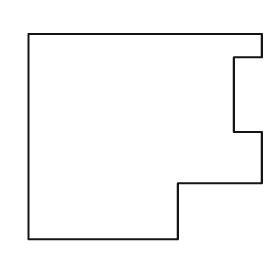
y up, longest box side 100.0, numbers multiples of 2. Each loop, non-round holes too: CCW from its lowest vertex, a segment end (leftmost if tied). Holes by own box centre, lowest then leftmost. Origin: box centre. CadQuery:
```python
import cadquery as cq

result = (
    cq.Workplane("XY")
    .moveTo(-50.0, -44.0)
    .lineTo(14.0, -44.0)
    .lineTo(14.0, -20.0)
    .lineTo(50.0, -20.0)
    .lineTo(50.0, 2.0)
    .lineTo(38.0, 2.0)
    .lineTo(38.0, 34.0)
    .lineTo(50.0, 34.0)
    .lineTo(50.0, 44.0)
    .lineTo(-50.0, 44.0)
    .close()
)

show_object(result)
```